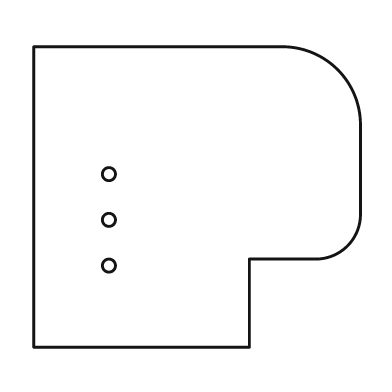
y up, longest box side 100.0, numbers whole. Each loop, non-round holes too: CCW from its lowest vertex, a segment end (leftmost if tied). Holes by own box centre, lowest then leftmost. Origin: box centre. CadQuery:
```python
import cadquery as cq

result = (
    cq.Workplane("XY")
    .moveTo(-50.0, -46.0)
    .lineTo(16.0, -46.0)
    .lineTo(16.0, -19.0)
    .lineTo(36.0, -19.0)
    .threePointArc((46.0, -15.0), (50.0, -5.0))
    .lineTo(50.0, 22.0)
    .threePointArc((43.0, 39.0), (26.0, 46.0))
    .lineTo(-50.0, 46.0)
    .close()
    .moveTo(-27.0, -21.0)
    .circle(2.0)
    .moveTo(-27.0, -7.0)
    .circle(2.0)
    .moveTo(-27.0, 7.0)
    .circle(2.0)
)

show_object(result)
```